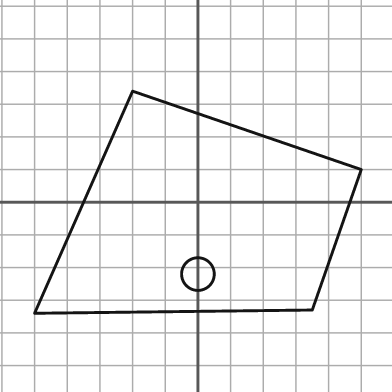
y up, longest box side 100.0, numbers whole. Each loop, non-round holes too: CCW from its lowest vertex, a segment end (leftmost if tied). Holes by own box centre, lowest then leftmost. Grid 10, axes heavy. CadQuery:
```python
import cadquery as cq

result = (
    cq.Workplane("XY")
    .moveTo(-50.0, -34.0)
    .lineTo(35.0, -33.0)
    .lineTo(50.0, 10.0)
    .lineTo(-20.0, 34.0)
    .close()
    .moveTo(0.0, -22.0)
    .circle(5.0)
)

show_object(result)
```